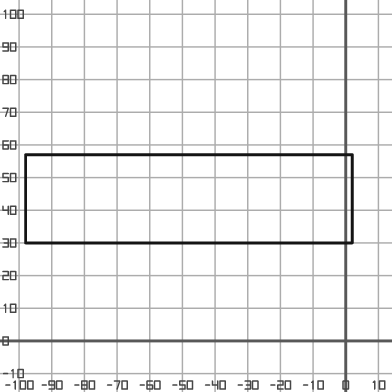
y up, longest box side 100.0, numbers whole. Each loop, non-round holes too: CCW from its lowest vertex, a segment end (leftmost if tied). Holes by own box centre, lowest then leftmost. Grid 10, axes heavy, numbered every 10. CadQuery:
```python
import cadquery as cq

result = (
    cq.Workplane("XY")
    .moveTo(-98.0, 30.0)
    .lineTo(2.0, 30.0)
    .lineTo(2.0, 57.0)
    .lineTo(-98.0, 57.0)
    .close()
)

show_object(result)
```